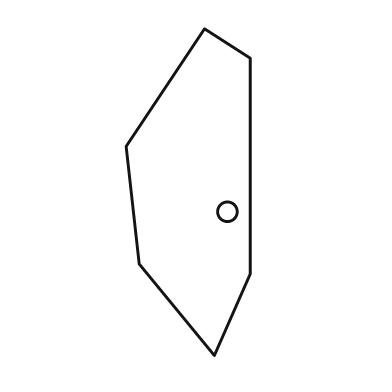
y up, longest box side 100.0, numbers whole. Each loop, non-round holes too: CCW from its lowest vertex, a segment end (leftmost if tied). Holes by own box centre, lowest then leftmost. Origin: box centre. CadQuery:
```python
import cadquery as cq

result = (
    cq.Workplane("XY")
    .moveTo(8.0, -50.0)
    .lineTo(19.0, -25.0)
    .lineTo(19.0, 41.0)
    .lineTo(5.0, 50.0)
    .lineTo(-19.0, 14.0)
    .lineTo(-15.0, -22.0)
    .close()
    .moveTo(12.0, -6.0)
    .circle(3.0)
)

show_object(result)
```